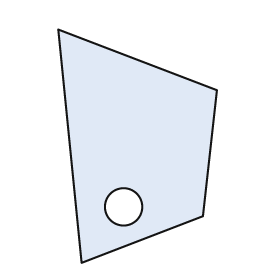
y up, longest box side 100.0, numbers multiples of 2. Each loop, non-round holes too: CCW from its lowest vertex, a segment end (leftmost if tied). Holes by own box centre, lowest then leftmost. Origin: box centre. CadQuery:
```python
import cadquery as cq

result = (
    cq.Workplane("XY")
    .moveTo(-24.0, -50.0)
    .lineTo(28.0, -30.0)
    .lineTo(34.0, 24.0)
    .lineTo(-34.0, 50.0)
    .close()
    .moveTo(-6.0, -26.0)
    .circle(8.0)
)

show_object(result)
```